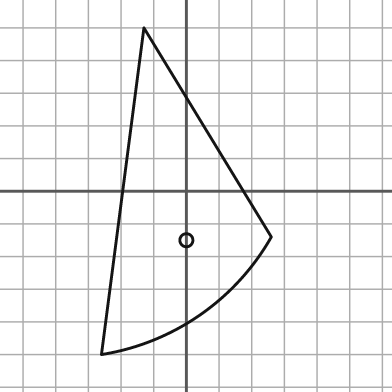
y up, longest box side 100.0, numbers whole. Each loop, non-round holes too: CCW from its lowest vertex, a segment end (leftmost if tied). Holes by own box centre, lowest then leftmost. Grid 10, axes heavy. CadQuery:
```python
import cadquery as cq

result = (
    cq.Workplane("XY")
    .moveTo(-26.0, -50.0)
    .threePointArc((4.0, -38.0), (26.0, -14.0))
    .lineTo(-13.0, 50.0)
    .close()
    .moveTo(0.0, -15.0)
    .circle(2.0)
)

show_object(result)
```